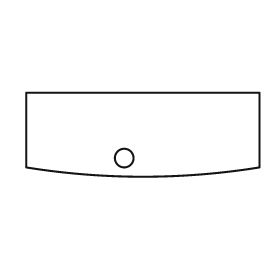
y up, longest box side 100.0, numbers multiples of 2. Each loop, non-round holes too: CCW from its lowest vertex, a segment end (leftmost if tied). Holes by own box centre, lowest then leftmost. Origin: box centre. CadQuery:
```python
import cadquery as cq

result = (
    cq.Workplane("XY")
    .moveTo(-50.0, -14.0)
    .threePointArc((0.0, -18.0), (50.0, -14.0))
    .lineTo(50.0, 18.0)
    .lineTo(-50.0, 18.0)
    .close()
    .moveTo(-8.0, -10.0)
    .circle(4.0)
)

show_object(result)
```